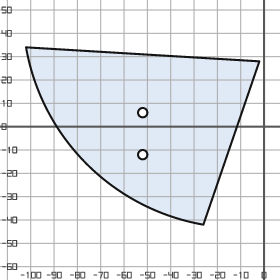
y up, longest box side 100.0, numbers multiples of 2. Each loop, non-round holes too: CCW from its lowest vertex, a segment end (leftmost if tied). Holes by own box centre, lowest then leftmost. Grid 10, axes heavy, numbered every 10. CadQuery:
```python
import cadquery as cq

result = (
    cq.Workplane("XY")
    .moveTo(-26.0, -42.0)
    .lineTo(-2.0, 28.0)
    .lineTo(-102.0, 34.0)
    .threePointArc((-76.0, -16.0), (-26.0, -42.0))
    .close()
    .moveTo(-52.0, -12.0)
    .circle(2.0)
    .moveTo(-52.0, 6.0)
    .circle(2.0)
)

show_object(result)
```